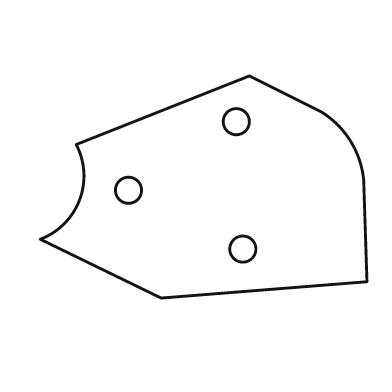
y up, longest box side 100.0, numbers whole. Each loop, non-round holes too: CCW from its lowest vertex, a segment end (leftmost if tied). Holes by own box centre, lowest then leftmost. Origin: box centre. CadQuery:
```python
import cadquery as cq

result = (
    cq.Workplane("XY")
    .moveTo(-13.0, -34.0)
    .lineTo(50.0, -29.0)
    .lineTo(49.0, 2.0)
    .threePointArc((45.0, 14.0), (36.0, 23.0))
    .lineTo(14.0, 34.0)
    .lineTo(-39.0, 13.0)
    .threePointArc((-38.0, -4.0), (-50.0, -16.0))
    .close()
    .moveTo(12.0, -19.0)
    .circle(4.0)
    .moveTo(-23.0, -1.0)
    .circle(4.0)
    .moveTo(10.0, 20.0)
    .circle(4.0)
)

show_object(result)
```